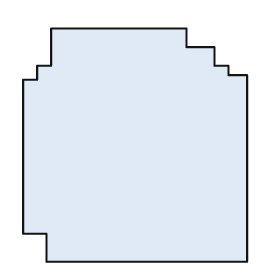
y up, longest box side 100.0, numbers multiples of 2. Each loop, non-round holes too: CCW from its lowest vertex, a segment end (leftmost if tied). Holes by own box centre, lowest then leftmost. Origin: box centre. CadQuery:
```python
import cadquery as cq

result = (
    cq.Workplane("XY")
    .moveTo(-38.0, -50.0)
    .lineTo(48.0, -50.0)
    .lineTo(48.0, 30.0)
    .lineTo(40.0, 30.0)
    .lineTo(40.0, 34.0)
    .lineTo(34.0, 34.0)
    .lineTo(34.0, 42.0)
    .lineTo(22.0, 42.0)
    .lineTo(22.0, 50.0)
    .lineTo(-36.0, 50.0)
    .lineTo(-36.0, 34.0)
    .lineTo(-42.0, 34.0)
    .lineTo(-42.0, 28.0)
    .lineTo(-48.0, 28.0)
    .lineTo(-48.0, -38.0)
    .lineTo(-38.0, -38.0)
    .close()
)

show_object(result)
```